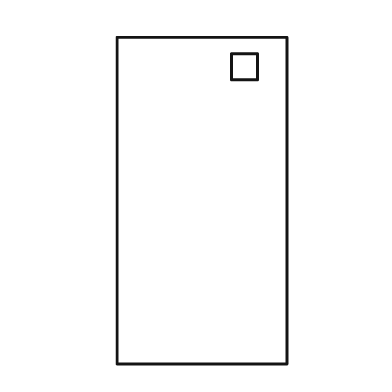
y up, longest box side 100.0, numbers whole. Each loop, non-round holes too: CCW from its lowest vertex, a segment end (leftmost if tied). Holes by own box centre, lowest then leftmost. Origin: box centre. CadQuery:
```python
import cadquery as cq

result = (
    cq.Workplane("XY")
    .moveTo(-26.0, -50.0)
    .lineTo(26.0, -50.0)
    .lineTo(26.0, 50.0)
    .lineTo(-26.0, 50.0)
    .close()
    .moveTo(9.0, 37.0)
    .lineTo(17.0, 37.0)
    .lineTo(17.0, 45.0)
    .lineTo(9.0, 45.0)
    .close()
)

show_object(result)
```